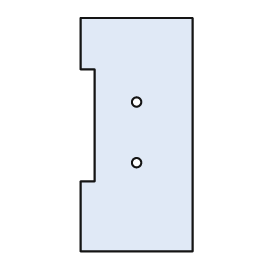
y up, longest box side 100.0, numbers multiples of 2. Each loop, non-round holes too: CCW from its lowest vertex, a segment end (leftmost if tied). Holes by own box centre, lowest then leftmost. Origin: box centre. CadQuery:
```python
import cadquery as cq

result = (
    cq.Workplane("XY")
    .moveTo(-24.0, -50.0)
    .lineTo(24.0, -50.0)
    .lineTo(24.0, 50.0)
    .lineTo(-24.0, 50.0)
    .lineTo(-24.0, 28.0)
    .lineTo(-18.0, 28.0)
    .lineTo(-18.0, -20.0)
    .lineTo(-24.0, -20.0)
    .close()
    .moveTo(0.0, -12.0)
    .circle(2.0)
    .moveTo(0.0, 14.0)
    .circle(2.0)
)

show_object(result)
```